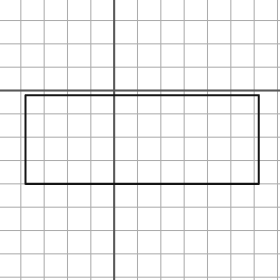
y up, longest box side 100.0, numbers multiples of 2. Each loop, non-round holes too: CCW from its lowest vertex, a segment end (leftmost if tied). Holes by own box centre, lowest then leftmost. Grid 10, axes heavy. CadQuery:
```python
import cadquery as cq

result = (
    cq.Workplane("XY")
    .moveTo(-38.0, -40.0)
    .lineTo(62.0, -40.0)
    .lineTo(62.0, -2.0)
    .lineTo(-38.0, -2.0)
    .close()
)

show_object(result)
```